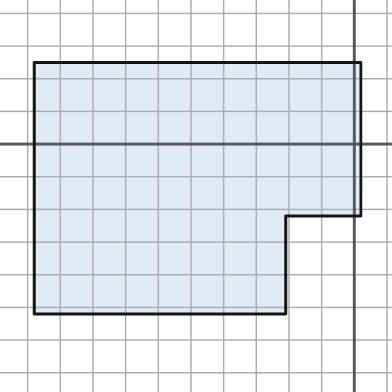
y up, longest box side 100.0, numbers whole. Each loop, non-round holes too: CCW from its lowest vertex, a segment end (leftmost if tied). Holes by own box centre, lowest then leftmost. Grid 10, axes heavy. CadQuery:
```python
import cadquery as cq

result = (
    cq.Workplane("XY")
    .moveTo(-98.0, -52.0)
    .lineTo(-21.0, -52.0)
    .lineTo(-21.0, -22.0)
    .lineTo(2.0, -22.0)
    .lineTo(2.0, 25.0)
    .lineTo(-98.0, 25.0)
    .close()
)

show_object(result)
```